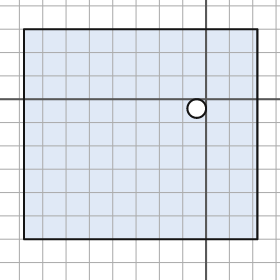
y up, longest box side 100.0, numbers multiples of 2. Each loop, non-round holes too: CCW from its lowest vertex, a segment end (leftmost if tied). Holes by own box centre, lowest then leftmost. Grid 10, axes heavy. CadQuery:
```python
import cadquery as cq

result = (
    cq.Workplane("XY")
    .moveTo(-78.0, -60.0)
    .lineTo(22.0, -60.0)
    .lineTo(22.0, 30.0)
    .lineTo(-78.0, 30.0)
    .close()
    .moveTo(-4.0, -4.0)
    .circle(4.0)
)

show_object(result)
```